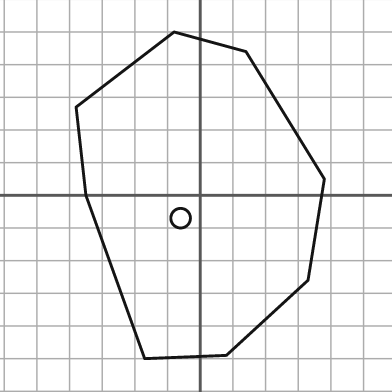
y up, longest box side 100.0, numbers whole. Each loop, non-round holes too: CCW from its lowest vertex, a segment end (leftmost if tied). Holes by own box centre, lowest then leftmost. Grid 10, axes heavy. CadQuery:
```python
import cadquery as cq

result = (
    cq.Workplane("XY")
    .moveTo(-17.0, -50.0)
    .lineTo(8.0, -49.0)
    .lineTo(33.0, -26.0)
    .lineTo(38.0, 5.0)
    .lineTo(14.0, 44.0)
    .lineTo(-8.0, 50.0)
    .lineTo(-38.0, 27.0)
    .lineTo(-35.0, 0.0)
    .close()
    .moveTo(-6.0, -7.0)
    .circle(3.0)
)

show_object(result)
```